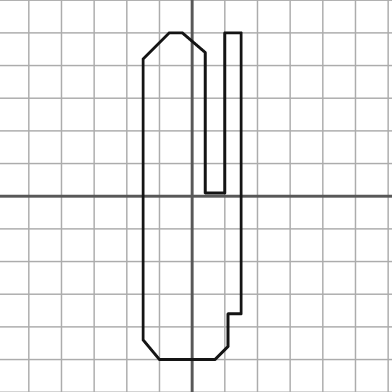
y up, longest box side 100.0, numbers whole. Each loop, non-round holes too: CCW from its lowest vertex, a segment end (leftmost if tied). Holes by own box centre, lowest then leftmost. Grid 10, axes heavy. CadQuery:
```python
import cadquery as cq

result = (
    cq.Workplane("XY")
    .moveTo(-10.0, -50.0)
    .lineTo(7.0, -50.0)
    .lineTo(11.0, -46.0)
    .lineTo(11.0, -36.0)
    .lineTo(15.0, -36.0)
    .lineTo(15.0, 50.0)
    .lineTo(10.0, 50.0)
    .lineTo(10.0, 1.0)
    .lineTo(4.0, 1.0)
    .lineTo(4.0, 44.0)
    .lineTo(-3.0, 50.0)
    .lineTo(-7.0, 50.0)
    .lineTo(-15.0, 42.0)
    .lineTo(-15.0, -44.0)
    .close()
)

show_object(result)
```